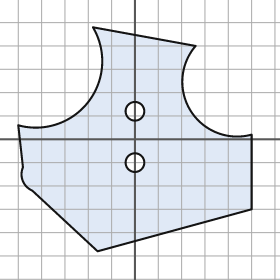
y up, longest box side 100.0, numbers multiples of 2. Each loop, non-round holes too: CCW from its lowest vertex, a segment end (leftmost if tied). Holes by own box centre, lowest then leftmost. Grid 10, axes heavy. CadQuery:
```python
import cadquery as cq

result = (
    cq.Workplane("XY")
    .moveTo(-16.0, -48.0)
    .lineTo(50.0, -30.0)
    .lineTo(50.0, 2.0)
    .threePointArc((24.0, 12.0), (26.0, 40.0))
    .lineTo(-18.0, 48.0)
    .threePointArc((-20.0, 16.0), (-50.0, 6.0))
    .lineTo(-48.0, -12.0)
    .threePointArc((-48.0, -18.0), (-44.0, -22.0))
    .close()
    .moveTo(0.0, -10.0)
    .circle(4.0)
    .moveTo(0.0, 12.0)
    .circle(4.0)
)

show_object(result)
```